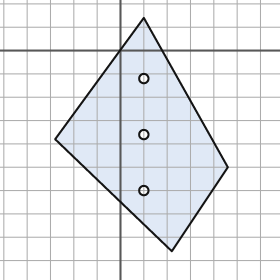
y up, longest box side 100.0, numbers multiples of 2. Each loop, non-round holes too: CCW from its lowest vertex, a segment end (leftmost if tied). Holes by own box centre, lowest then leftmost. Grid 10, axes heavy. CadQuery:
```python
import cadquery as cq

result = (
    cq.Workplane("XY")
    .moveTo(22.0, -86.0)
    .lineTo(46.0, -50.0)
    .lineTo(10.0, 14.0)
    .lineTo(-28.0, -38.0)
    .close()
    .moveTo(10.0, -60.0)
    .circle(2.0)
    .moveTo(10.0, -36.0)
    .circle(2.0)
    .moveTo(10.0, -12.0)
    .circle(2.0)
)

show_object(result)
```